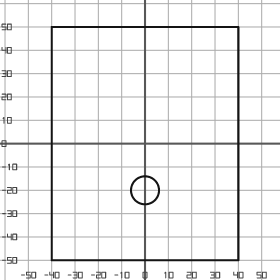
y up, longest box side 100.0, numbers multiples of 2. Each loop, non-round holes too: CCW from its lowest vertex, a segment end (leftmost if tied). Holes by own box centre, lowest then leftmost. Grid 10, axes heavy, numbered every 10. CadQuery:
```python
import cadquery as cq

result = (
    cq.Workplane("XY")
    .moveTo(-40.0, -50.0)
    .lineTo(40.0, -50.0)
    .lineTo(40.0, 50.0)
    .lineTo(-40.0, 50.0)
    .close()
    .moveTo(0.0, -20.0)
    .circle(6.0)
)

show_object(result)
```